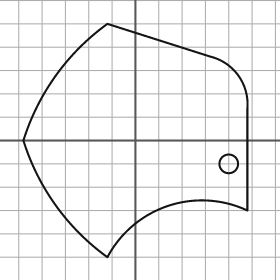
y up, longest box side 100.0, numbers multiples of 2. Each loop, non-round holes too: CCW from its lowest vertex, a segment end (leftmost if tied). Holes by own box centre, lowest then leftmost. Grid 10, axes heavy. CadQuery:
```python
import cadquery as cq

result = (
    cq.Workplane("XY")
    .moveTo(-12.0, -50.0)
    .threePointArc((14.0, -28.0), (48.0, -30.0))
    .lineTo(48.0, 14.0)
    .threePointArc((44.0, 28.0), (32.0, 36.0))
    .lineTo(-12.0, 50.0)
    .threePointArc((-34.0, 28.0), (-48.0, 0.0))
    .threePointArc((-34.0, -28.0), (-12.0, -50.0))
    .close()
    .moveTo(40.0, -10.0)
    .circle(4.0)
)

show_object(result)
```